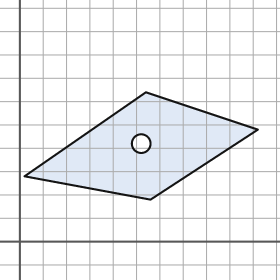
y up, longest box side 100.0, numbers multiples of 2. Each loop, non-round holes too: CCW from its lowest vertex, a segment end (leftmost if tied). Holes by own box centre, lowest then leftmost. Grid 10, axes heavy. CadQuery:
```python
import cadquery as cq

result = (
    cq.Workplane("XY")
    .moveTo(56.0, 18.0)
    .lineTo(102.0, 48.0)
    .lineTo(54.0, 64.0)
    .lineTo(2.0, 28.0)
    .close()
    .moveTo(52.0, 42.0)
    .circle(4.0)
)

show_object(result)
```